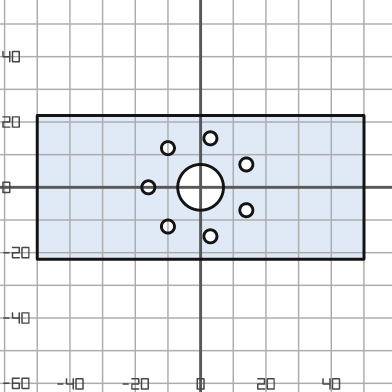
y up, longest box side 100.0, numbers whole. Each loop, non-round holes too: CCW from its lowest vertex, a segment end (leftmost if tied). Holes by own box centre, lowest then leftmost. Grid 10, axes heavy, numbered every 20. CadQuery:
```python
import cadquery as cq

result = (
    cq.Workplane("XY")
    .moveTo(-50.0, -22.0)
    .lineTo(50.0, -22.0)
    .lineTo(50.0, 22.0)
    .lineTo(-50.0, 22.0)
    .close()
    .moveTo(3.0, -15.0)
    .circle(2.0)
    .moveTo(-10.0, -12.0)
    .circle(2.0)
    .moveTo(14.0, -7.0)
    .circle(2.0)
    .moveTo(-16.0, 0.0)
    .circle(2.0)
    .moveTo(0.0, 0.0)
    .circle(7.0)
    .moveTo(14.0, 7.0)
    .circle(2.0)
    .moveTo(-10.0, 12.0)
    .circle(2.0)
    .moveTo(3.0, 15.0)
    .circle(2.0)
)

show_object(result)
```